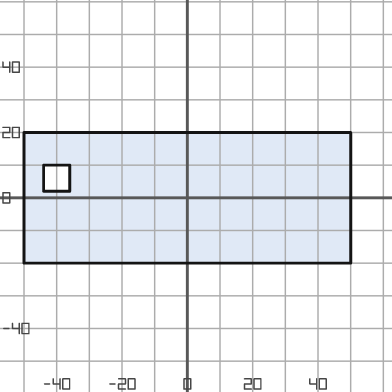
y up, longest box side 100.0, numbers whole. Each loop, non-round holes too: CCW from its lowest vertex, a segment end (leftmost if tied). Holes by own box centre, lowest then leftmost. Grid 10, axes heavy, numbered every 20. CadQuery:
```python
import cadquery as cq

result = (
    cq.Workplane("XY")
    .moveTo(-50.0, -20.0)
    .lineTo(50.0, -20.0)
    .lineTo(50.0, 20.0)
    .lineTo(-50.0, 20.0)
    .close()
    .moveTo(-44.0, 2.0)
    .lineTo(-36.0, 2.0)
    .lineTo(-36.0, 10.0)
    .lineTo(-44.0, 10.0)
    .close()
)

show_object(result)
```